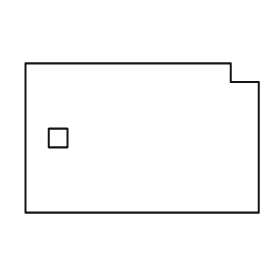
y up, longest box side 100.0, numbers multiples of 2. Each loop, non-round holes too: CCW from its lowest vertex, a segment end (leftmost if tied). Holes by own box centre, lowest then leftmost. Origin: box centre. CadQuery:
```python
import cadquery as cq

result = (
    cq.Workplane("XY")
    .moveTo(-50.0, -32.0)
    .lineTo(50.0, -32.0)
    .lineTo(50.0, 24.0)
    .lineTo(38.0, 24.0)
    .lineTo(38.0, 32.0)
    .lineTo(-50.0, 32.0)
    .close()
    .moveTo(-40.0, -4.0)
    .lineTo(-32.0, -4.0)
    .lineTo(-32.0, 4.0)
    .lineTo(-40.0, 4.0)
    .close()
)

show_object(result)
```